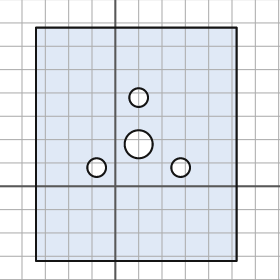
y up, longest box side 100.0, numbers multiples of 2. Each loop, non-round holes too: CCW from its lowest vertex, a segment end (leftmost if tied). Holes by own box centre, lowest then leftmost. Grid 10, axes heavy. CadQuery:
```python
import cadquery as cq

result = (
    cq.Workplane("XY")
    .moveTo(-34.0, -32.0)
    .lineTo(52.0, -32.0)
    .lineTo(52.0, 68.0)
    .lineTo(-34.0, 68.0)
    .close()
    .moveTo(-8.0, 8.0)
    .circle(4.0)
    .moveTo(28.0, 8.0)
    .circle(4.0)
    .moveTo(10.0, 18.0)
    .circle(6.0)
    .moveTo(10.0, 38.0)
    .circle(4.0)
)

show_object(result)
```